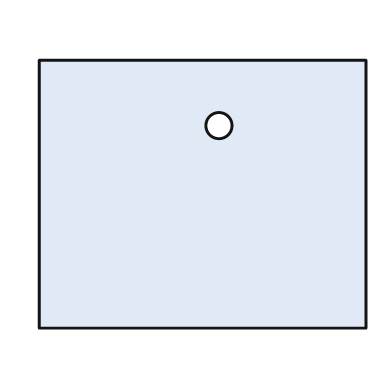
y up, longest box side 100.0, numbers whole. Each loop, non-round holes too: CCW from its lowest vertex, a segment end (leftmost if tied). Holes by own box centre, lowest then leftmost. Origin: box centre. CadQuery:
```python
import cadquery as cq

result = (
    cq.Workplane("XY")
    .moveTo(-50.0, -41.0)
    .lineTo(50.0, -41.0)
    .lineTo(50.0, 41.0)
    .lineTo(-50.0, 41.0)
    .close()
    .moveTo(5.0, 21.0)
    .circle(4.0)
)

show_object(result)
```